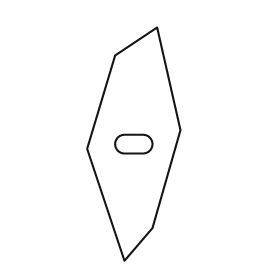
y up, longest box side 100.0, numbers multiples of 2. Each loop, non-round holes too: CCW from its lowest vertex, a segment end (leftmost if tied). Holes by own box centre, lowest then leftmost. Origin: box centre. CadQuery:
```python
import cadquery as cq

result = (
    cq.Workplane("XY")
    .moveTo(-4.0, -50.0)
    .lineTo(8.0, -36.0)
    .lineTo(20.0, 6.0)
    .lineTo(10.0, 50.0)
    .lineTo(-8.0, 38.0)
    .lineTo(-20.0, -2.0)
    .close()
    .moveTo(-4.0, -4.0)
    .lineTo(4.0, -4.0)
    .threePointArc((8.0, 0.0), (4.0, 4.0))
    .lineTo(-4.0, 4.0)
    .threePointArc((-8.0, 0.0), (-4.0, -4.0))
    .close()
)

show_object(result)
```